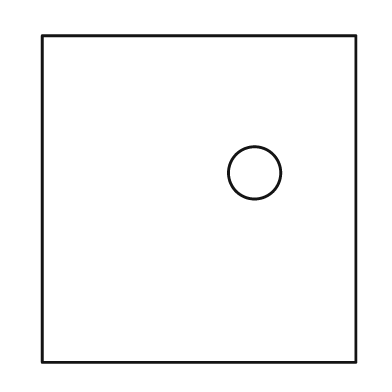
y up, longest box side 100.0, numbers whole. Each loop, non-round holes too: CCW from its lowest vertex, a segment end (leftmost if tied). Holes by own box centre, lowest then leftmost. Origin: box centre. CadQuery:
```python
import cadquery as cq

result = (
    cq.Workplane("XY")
    .moveTo(-48.0, -50.0)
    .lineTo(48.0, -50.0)
    .lineTo(48.0, 50.0)
    .lineTo(-48.0, 50.0)
    .close()
    .moveTo(17.0, 8.0)
    .circle(8.0)
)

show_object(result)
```